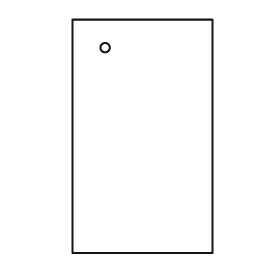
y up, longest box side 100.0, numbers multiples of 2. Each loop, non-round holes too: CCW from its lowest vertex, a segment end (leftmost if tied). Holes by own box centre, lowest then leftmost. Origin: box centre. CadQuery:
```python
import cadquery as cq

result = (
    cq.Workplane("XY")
    .moveTo(-30.0, -50.0)
    .lineTo(30.0, -50.0)
    .lineTo(30.0, 50.0)
    .lineTo(-30.0, 50.0)
    .close()
    .moveTo(-16.0, 38.0)
    .circle(2.0)
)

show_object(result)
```